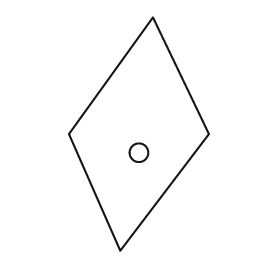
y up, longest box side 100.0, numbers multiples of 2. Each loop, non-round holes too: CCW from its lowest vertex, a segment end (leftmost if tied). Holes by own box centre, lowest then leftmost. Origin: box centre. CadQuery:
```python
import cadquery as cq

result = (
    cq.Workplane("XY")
    .moveTo(-8.0, -50.0)
    .lineTo(30.0, 0.0)
    .lineTo(6.0, 50.0)
    .lineTo(-30.0, 0.0)
    .close()
    .moveTo(0.0, -8.0)
    .circle(4.0)
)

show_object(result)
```